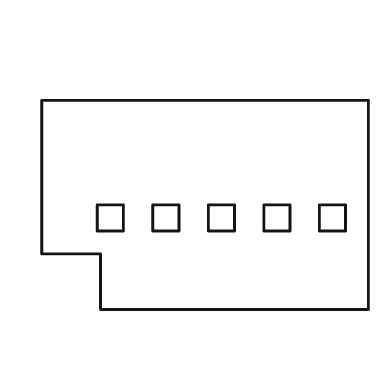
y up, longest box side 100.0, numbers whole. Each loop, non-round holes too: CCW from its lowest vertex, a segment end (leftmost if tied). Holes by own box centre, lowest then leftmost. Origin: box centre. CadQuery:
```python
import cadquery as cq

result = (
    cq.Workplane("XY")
    .moveTo(-32.0, -32.0)
    .lineTo(50.0, -32.0)
    .lineTo(50.0, 32.0)
    .lineTo(-50.0, 32.0)
    .lineTo(-50.0, -15.0)
    .lineTo(-32.0, -15.0)
    .close()
    .moveTo(-33.0, -8.0)
    .lineTo(-25.0, -8.0)
    .lineTo(-25.0, 0.0)
    .lineTo(-33.0, 0.0)
    .close()
    .moveTo(-16.0, -8.0)
    .lineTo(-8.0, -8.0)
    .lineTo(-8.0, 0.0)
    .lineTo(-16.0, 0.0)
    .close()
    .moveTo(1.0, -8.0)
    .lineTo(9.0, -8.0)
    .lineTo(9.0, 0.0)
    .lineTo(1.0, 0.0)
    .close()
    .moveTo(18.0, -8.0)
    .lineTo(26.0, -8.0)
    .lineTo(26.0, 0.0)
    .lineTo(18.0, 0.0)
    .close()
    .moveTo(35.0, -8.0)
    .lineTo(43.0, -8.0)
    .lineTo(43.0, 0.0)
    .lineTo(35.0, 0.0)
    .close()
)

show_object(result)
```